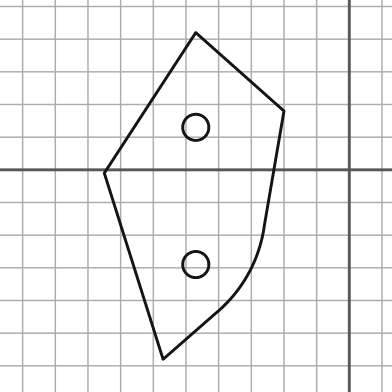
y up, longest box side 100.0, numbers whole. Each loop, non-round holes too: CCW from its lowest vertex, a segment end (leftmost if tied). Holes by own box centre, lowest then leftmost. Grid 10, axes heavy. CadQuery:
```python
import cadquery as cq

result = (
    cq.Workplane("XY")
    .moveTo(-57.0, -58.0)
    .lineTo(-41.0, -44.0)
    .threePointArc((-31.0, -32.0), (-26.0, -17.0))
    .lineTo(-20.0, 18.0)
    .lineTo(-47.0, 42.0)
    .lineTo(-75.0, -1.0)
    .close()
    .moveTo(-47.0, -29.0)
    .circle(4.0)
    .moveTo(-47.0, 13.0)
    .circle(4.0)
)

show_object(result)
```